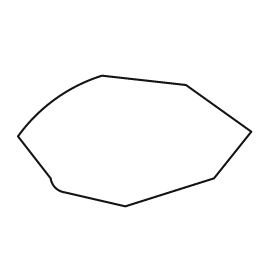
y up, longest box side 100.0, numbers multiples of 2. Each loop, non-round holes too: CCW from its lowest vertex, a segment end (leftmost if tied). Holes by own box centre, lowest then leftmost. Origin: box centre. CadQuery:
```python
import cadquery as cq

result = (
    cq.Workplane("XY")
    .moveTo(-4.0, -28.0)
    .lineTo(34.0, -16.0)
    .lineTo(50.0, 4.0)
    .lineTo(22.0, 24.0)
    .lineTo(-14.0, 28.0)
    .threePointArc((-34.0, 18.0), (-50.0, 2.0))
    .lineTo(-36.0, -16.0)
    .threePointArc((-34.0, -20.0), (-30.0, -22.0))
    .close()
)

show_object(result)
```